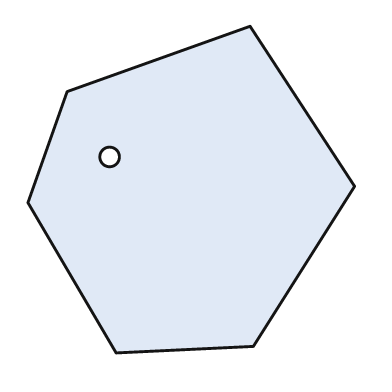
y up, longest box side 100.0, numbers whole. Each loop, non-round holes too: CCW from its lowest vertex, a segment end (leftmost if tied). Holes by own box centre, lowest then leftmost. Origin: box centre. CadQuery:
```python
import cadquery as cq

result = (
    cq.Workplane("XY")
    .moveTo(-23.0, -50.0)
    .lineTo(19.0, -48.0)
    .lineTo(50.0, 1.0)
    .lineTo(18.0, 50.0)
    .lineTo(-38.0, 30.0)
    .lineTo(-50.0, -4.0)
    .close()
    .moveTo(-25.0, 10.0)
    .circle(3.0)
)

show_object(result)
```